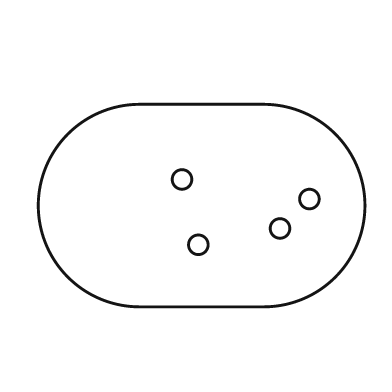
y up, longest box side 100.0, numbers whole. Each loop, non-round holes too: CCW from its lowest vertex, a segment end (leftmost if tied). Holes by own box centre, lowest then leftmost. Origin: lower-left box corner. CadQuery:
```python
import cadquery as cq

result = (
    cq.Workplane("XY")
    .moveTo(31.0, 0.0)
    .lineTo(69.0, 0.0)
    .threePointArc((100.0, 31.0), (69.0, 62.0))
    .lineTo(31.0, 62.0)
    .threePointArc((0.0, 31.0), (31.0, 0.0))
    .close()
    .moveTo(49.0, 19.0)
    .circle(3.0)
    .moveTo(74.0, 24.0)
    .circle(3.0)
    .moveTo(83.0, 33.0)
    .circle(3.0)
    .moveTo(44.0, 39.0)
    .circle(3.0)
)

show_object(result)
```